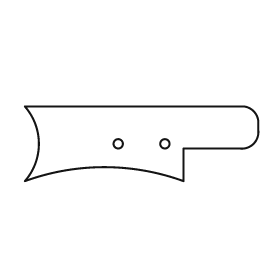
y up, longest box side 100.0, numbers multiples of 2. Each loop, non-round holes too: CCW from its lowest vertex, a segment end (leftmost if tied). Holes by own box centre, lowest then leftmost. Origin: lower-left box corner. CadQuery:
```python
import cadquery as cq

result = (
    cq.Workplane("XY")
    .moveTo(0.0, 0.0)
    .threePointArc((34.0, 6.0), (68.0, 0.0))
    .lineTo(68.0, 14.0)
    .lineTo(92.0, 14.0)
    .threePointArc((98.0, 16.0), (100.0, 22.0))
    .lineTo(100.0, 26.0)
    .threePointArc((98.0, 30.0), (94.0, 32.0))
    .lineTo(0.0, 32.0)
    .threePointArc((6.0, 16.0), (0.0, 0.0))
    .close()
    .moveTo(40.0, 16.0)
    .circle(2.0)
    .moveTo(60.0, 16.0)
    .circle(2.0)
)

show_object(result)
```